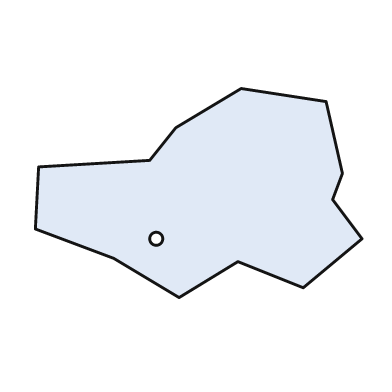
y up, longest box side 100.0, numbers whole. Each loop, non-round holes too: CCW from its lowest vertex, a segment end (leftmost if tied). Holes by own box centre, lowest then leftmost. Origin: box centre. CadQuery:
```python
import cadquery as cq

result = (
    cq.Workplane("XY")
    .moveTo(-6.0, -32.0)
    .lineTo(12.0, -21.0)
    .lineTo(32.0, -29.0)
    .lineTo(50.0, -14.0)
    .lineTo(41.0, -2.0)
    .lineTo(44.0, 6.0)
    .lineTo(39.0, 28.0)
    .lineTo(13.0, 32.0)
    .lineTo(-7.0, 20.0)
    .lineTo(-15.0, 10.0)
    .lineTo(-49.0, 8.0)
    .lineTo(-50.0, -11.0)
    .lineTo(-26.0, -20.0)
    .close()
    .moveTo(-13.0, -14.0)
    .circle(2.0)
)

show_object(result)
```